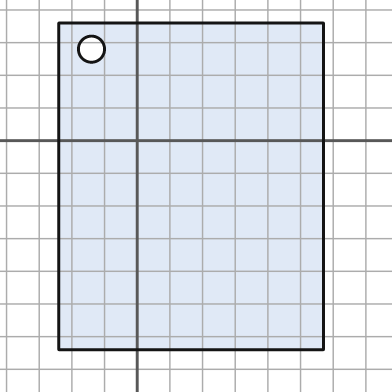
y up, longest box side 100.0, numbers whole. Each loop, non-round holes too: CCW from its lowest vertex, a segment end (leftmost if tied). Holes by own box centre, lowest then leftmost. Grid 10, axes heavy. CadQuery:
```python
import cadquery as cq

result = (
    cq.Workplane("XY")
    .moveTo(-24.0, -64.0)
    .lineTo(57.0, -64.0)
    .lineTo(57.0, 36.0)
    .lineTo(-24.0, 36.0)
    .close()
    .moveTo(-14.0, 28.0)
    .circle(4.0)
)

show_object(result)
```